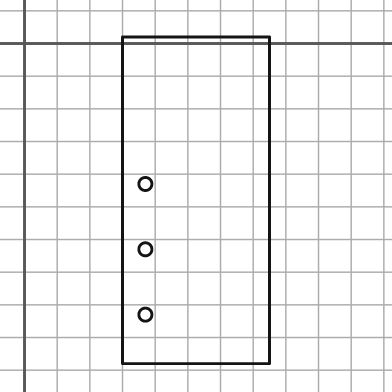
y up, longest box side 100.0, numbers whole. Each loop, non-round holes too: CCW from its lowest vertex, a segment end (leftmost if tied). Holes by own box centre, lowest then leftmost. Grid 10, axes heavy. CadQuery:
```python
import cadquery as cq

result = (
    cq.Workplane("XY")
    .moveTo(30.0, -98.0)
    .lineTo(75.0, -98.0)
    .lineTo(75.0, 2.0)
    .lineTo(30.0, 2.0)
    .close()
    .moveTo(37.0, -83.0)
    .circle(2.0)
    .moveTo(37.0, -63.0)
    .circle(2.0)
    .moveTo(37.0, -43.0)
    .circle(2.0)
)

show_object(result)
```